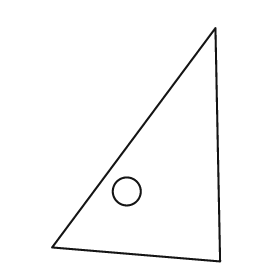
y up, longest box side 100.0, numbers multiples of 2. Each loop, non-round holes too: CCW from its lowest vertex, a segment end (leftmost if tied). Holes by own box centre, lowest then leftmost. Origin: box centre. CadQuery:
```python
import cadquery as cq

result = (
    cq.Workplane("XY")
    .moveTo(36.0, -50.0)
    .lineTo(34.0, 50.0)
    .lineTo(-36.0, -44.0)
    .close()
    .moveTo(-4.0, -20.0)
    .circle(6.0)
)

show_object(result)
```